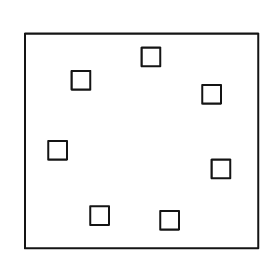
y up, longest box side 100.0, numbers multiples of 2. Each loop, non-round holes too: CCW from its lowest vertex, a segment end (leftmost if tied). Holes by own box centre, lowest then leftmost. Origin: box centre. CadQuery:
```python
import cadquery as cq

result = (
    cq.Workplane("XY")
    .moveTo(-50.0, -46.0)
    .lineTo(50.0, -46.0)
    .lineTo(50.0, 46.0)
    .lineTo(-50.0, 46.0)
    .close()
    .moveTo(8.0, -38.0)
    .lineTo(16.0, -38.0)
    .lineTo(16.0, -30.0)
    .lineTo(8.0, -30.0)
    .close()
    .moveTo(-22.0, -36.0)
    .lineTo(-14.0, -36.0)
    .lineTo(-14.0, -28.0)
    .lineTo(-22.0, -28.0)
    .close()
    .moveTo(30.0, -16.0)
    .lineTo(38.0, -16.0)
    .lineTo(38.0, -8.0)
    .lineTo(30.0, -8.0)
    .close()
    .moveTo(-40.0, -8.0)
    .lineTo(-32.0, -8.0)
    .lineTo(-32.0, 0.0)
    .lineTo(-40.0, 0.0)
    .close()
    .moveTo(26.0, 16.0)
    .lineTo(34.0, 16.0)
    .lineTo(34.0, 24.0)
    .lineTo(26.0, 24.0)
    .close()
    .moveTo(-30.0, 22.0)
    .lineTo(-22.0, 22.0)
    .lineTo(-22.0, 30.0)
    .lineTo(-30.0, 30.0)
    .close()
    .moveTo(0.0, 32.0)
    .lineTo(8.0, 32.0)
    .lineTo(8.0, 40.0)
    .lineTo(0.0, 40.0)
    .close()
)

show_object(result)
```